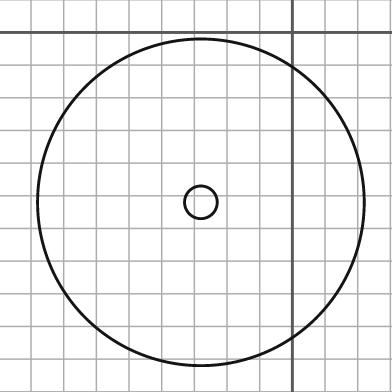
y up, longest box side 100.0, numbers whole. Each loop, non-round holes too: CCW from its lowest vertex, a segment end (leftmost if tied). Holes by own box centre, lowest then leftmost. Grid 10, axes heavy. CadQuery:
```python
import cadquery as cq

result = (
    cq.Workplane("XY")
    .moveTo(-28.0, -52.0)
    .circle(50.0)
    .moveTo(-28.0, -52.0)
    .circle(5.0)
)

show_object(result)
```